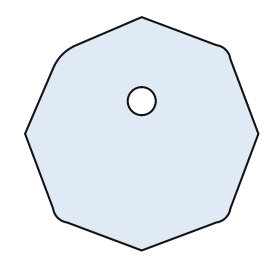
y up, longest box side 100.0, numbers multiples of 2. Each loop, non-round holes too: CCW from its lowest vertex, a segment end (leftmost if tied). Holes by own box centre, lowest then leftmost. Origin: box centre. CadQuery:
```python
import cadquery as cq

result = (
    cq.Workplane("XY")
    .moveTo(0.0, -50.0)
    .lineTo(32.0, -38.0)
    .threePointArc((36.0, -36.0), (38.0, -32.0))
    .lineTo(50.0, 0.0)
    .lineTo(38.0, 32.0)
    .threePointArc((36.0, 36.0), (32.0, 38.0))
    .lineTo(0.0, 50.0)
    .lineTo(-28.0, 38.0)
    .threePointArc((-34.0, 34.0), (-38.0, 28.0))
    .lineTo(-50.0, 0.0)
    .lineTo(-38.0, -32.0)
    .threePointArc((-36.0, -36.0), (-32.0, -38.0))
    .close()
    .moveTo(0.0, 14.0)
    .circle(6.0)
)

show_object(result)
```